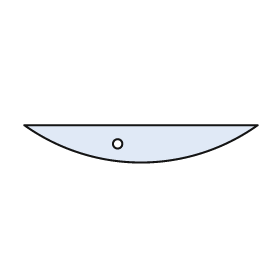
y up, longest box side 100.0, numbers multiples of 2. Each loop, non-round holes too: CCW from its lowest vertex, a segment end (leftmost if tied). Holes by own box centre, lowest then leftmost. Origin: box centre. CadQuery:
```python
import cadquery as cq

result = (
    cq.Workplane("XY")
    .moveTo(-50.0, 8.0)
    .threePointArc((0.0, -8.0), (50.0, 8.0))
    .close()
    .moveTo(-10.0, 0.0)
    .circle(2.0)
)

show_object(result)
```